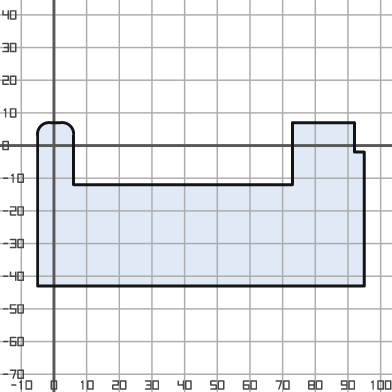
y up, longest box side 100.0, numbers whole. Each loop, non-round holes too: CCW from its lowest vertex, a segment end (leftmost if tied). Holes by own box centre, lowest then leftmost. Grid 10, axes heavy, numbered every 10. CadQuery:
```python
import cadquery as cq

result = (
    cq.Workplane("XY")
    .moveTo(-5.0, -43.0)
    .lineTo(95.0, -43.0)
    .lineTo(95.0, -2.0)
    .lineTo(92.0, -2.0)
    .lineTo(92.0, 7.0)
    .lineTo(73.0, 7.0)
    .lineTo(73.0, -12.0)
    .lineTo(6.0, -12.0)
    .lineTo(6.0, 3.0)
    .threePointArc((5.0, 6.0), (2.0, 7.0))
    .lineTo(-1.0, 7.0)
    .threePointArc((-4.0, 6.0), (-5.0, 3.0))
    .close()
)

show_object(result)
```